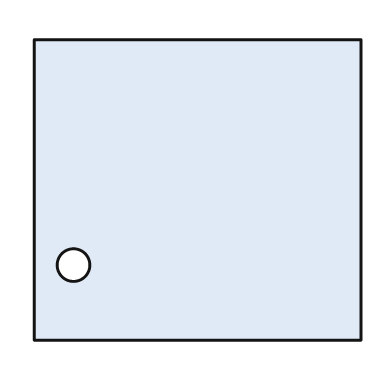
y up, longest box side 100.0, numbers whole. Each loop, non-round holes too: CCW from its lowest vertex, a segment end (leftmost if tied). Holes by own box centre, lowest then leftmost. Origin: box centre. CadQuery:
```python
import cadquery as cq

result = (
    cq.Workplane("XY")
    .moveTo(-50.0, -46.0)
    .lineTo(50.0, -46.0)
    .lineTo(50.0, 46.0)
    .lineTo(-50.0, 46.0)
    .close()
    .moveTo(-38.0, -23.0)
    .circle(5.0)
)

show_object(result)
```